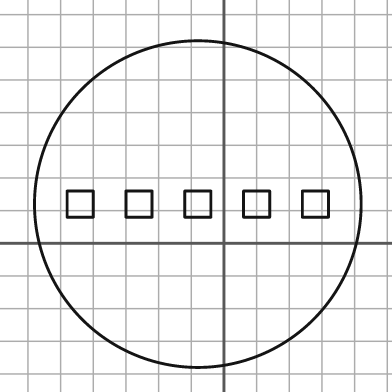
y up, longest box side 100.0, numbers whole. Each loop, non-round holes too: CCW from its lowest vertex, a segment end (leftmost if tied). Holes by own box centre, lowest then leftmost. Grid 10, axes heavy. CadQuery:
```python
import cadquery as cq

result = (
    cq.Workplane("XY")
    .moveTo(-8.0, 12.0)
    .circle(50.0)
    .moveTo(-48.0, 8.0)
    .lineTo(-40.0, 8.0)
    .lineTo(-40.0, 16.0)
    .lineTo(-48.0, 16.0)
    .close()
    .moveTo(-30.0, 8.0)
    .lineTo(-22.0, 8.0)
    .lineTo(-22.0, 16.0)
    .lineTo(-30.0, 16.0)
    .close()
    .moveTo(-12.0, 8.0)
    .lineTo(-4.0, 8.0)
    .lineTo(-4.0, 16.0)
    .lineTo(-12.0, 16.0)
    .close()
    .moveTo(6.0, 8.0)
    .lineTo(14.0, 8.0)
    .lineTo(14.0, 16.0)
    .lineTo(6.0, 16.0)
    .close()
    .moveTo(24.0, 8.0)
    .lineTo(32.0, 8.0)
    .lineTo(32.0, 16.0)
    .lineTo(24.0, 16.0)
    .close()
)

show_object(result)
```